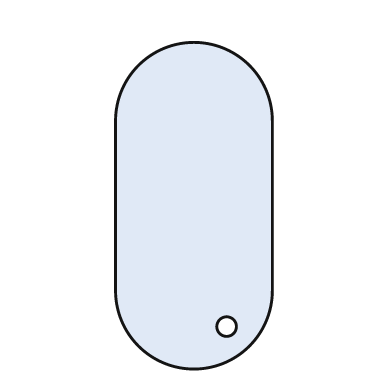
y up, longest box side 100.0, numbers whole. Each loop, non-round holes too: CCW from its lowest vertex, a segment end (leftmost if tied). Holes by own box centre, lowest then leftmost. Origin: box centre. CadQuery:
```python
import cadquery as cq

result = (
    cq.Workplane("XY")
    .moveTo(-24.0, -26.0)
    .threePointArc((0.0, -50.0), (24.0, -26.0))
    .lineTo(24.0, 26.0)
    .threePointArc((0.0, 50.0), (-24.0, 26.0))
    .close()
    .moveTo(10.0, -37.0)
    .circle(3.0)
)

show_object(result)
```